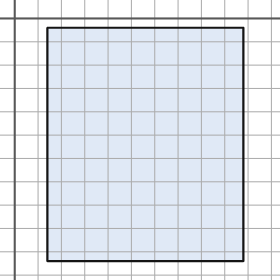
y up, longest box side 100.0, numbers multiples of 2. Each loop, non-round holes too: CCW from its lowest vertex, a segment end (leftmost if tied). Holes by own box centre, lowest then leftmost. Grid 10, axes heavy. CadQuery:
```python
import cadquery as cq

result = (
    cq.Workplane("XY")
    .moveTo(14.0, -104.0)
    .lineTo(98.0, -104.0)
    .lineTo(98.0, -4.0)
    .lineTo(14.0, -4.0)
    .close()
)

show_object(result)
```